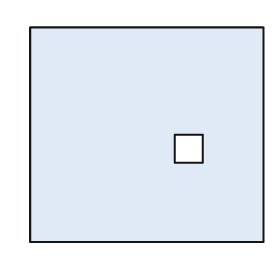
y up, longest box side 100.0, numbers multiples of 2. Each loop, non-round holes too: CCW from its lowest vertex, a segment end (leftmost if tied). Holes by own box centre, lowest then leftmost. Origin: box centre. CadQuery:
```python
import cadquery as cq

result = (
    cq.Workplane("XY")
    .moveTo(-50.0, -46.0)
    .lineTo(50.0, -46.0)
    .lineTo(50.0, 46.0)
    .lineTo(-50.0, 46.0)
    .close()
    .moveTo(12.0, -12.0)
    .lineTo(24.0, -12.0)
    .lineTo(24.0, 0.0)
    .lineTo(12.0, 0.0)
    .close()
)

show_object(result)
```